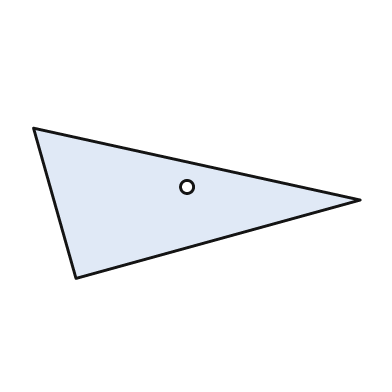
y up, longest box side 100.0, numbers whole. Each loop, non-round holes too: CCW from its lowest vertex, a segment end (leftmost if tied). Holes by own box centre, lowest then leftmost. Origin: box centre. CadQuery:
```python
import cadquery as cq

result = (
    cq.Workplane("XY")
    .moveTo(-37.0, -23.0)
    .lineTo(50.0, 1.0)
    .lineTo(-50.0, 23.0)
    .close()
    .moveTo(-3.0, 5.0)
    .circle(2.0)
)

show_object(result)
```